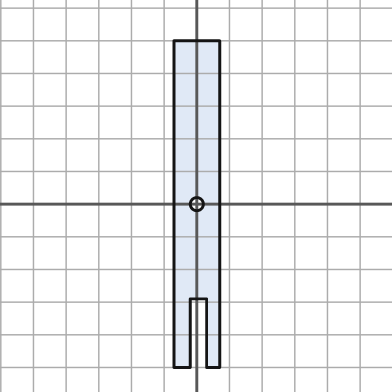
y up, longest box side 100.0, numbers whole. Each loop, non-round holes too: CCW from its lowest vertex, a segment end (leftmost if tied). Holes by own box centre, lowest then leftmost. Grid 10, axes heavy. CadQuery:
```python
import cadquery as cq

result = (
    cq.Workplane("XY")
    .moveTo(-7.0, -50.0)
    .lineTo(-2.0, -50.0)
    .lineTo(-2.0, -29.0)
    .lineTo(3.0, -29.0)
    .lineTo(3.0, -50.0)
    .lineTo(7.0, -50.0)
    .lineTo(7.0, 50.0)
    .lineTo(-7.0, 50.0)
    .close()
    .moveTo(0.0, 0.0)
    .circle(2.0)
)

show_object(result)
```